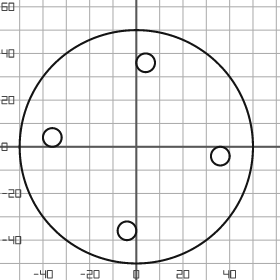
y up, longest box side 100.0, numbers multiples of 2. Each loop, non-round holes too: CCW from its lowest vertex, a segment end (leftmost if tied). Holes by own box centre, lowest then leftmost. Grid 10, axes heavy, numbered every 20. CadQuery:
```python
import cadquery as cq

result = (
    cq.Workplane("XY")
    .moveTo(0.0, 0.0)
    .circle(50.0)
    .moveTo(-4.0, -36.0)
    .circle(4.0)
    .moveTo(36.0, -4.0)
    .circle(4.0)
    .moveTo(-36.0, 4.0)
    .circle(4.0)
    .moveTo(4.0, 36.0)
    .circle(4.0)
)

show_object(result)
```